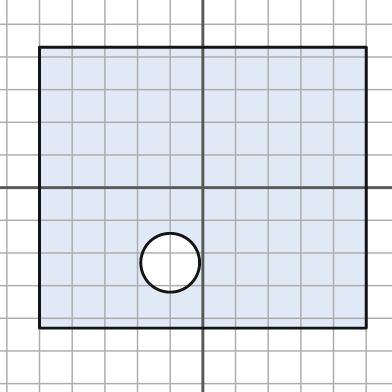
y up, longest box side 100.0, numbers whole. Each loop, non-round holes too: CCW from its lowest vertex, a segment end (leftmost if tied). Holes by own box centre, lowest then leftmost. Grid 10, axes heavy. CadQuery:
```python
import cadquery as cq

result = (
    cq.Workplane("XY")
    .moveTo(-50.0, -43.0)
    .lineTo(50.0, -43.0)
    .lineTo(50.0, 43.0)
    .lineTo(-50.0, 43.0)
    .close()
    .moveTo(-10.0, -23.0)
    .circle(9.0)
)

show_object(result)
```